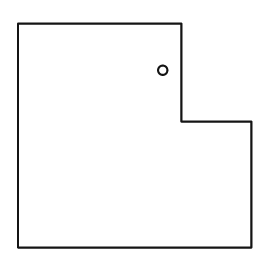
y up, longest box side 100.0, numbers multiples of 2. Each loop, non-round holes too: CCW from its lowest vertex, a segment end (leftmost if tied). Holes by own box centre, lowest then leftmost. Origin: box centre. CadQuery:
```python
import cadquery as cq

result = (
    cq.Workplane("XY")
    .moveTo(-50.0, -48.0)
    .lineTo(50.0, -48.0)
    .lineTo(50.0, 6.0)
    .lineTo(20.0, 6.0)
    .lineTo(20.0, 48.0)
    .lineTo(-50.0, 48.0)
    .close()
    .moveTo(12.0, 28.0)
    .circle(2.0)
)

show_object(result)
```